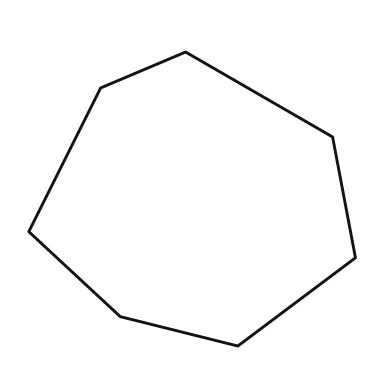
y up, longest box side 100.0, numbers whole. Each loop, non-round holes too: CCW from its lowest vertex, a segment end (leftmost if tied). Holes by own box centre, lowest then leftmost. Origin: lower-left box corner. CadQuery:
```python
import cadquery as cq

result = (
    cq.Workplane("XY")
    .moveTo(64.0, 0.0)
    .lineTo(100.0, 27.0)
    .lineTo(93.0, 64.0)
    .lineTo(48.0, 90.0)
    .lineTo(22.0, 79.0)
    .lineTo(0.0, 35.0)
    .lineTo(28.0, 9.0)
    .close()
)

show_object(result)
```